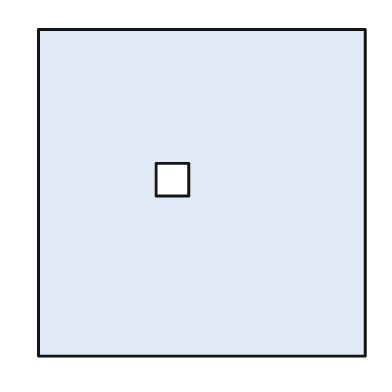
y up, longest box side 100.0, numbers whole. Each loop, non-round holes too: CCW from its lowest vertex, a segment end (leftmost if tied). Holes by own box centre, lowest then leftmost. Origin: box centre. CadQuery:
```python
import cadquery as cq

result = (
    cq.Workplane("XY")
    .moveTo(-50.0, -50.0)
    .lineTo(50.0, -50.0)
    .lineTo(50.0, 50.0)
    .lineTo(-50.0, 50.0)
    .close()
    .moveTo(-14.0, -1.0)
    .lineTo(-4.0, -1.0)
    .lineTo(-4.0, 9.0)
    .lineTo(-14.0, 9.0)
    .close()
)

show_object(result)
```